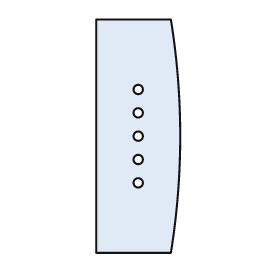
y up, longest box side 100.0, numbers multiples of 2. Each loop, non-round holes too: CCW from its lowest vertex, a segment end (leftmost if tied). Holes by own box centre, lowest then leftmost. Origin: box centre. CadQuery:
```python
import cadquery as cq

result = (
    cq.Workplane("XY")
    .moveTo(-18.0, -50.0)
    .lineTo(14.0, -50.0)
    .threePointArc((18.0, 0.0), (14.0, 50.0))
    .lineTo(-18.0, 50.0)
    .close()
    .moveTo(0.0, -20.0)
    .circle(2.0)
    .moveTo(0.0, -10.0)
    .circle(2.0)
    .moveTo(0.0, 0.0)
    .circle(2.0)
    .moveTo(0.0, 10.0)
    .circle(2.0)
    .moveTo(0.0, 20.0)
    .circle(2.0)
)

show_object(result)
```